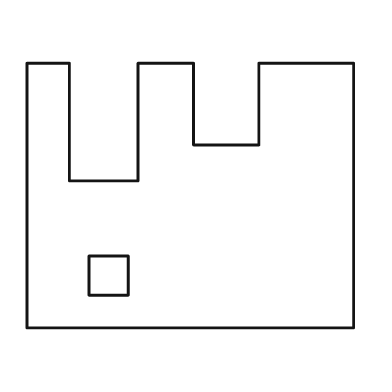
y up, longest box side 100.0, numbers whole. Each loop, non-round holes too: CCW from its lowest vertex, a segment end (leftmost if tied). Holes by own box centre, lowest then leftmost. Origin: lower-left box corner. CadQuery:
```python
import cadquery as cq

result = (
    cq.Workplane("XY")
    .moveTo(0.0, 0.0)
    .lineTo(100.0, 0.0)
    .lineTo(100.0, 81.0)
    .lineTo(71.0, 81.0)
    .lineTo(71.0, 56.0)
    .lineTo(51.0, 56.0)
    .lineTo(51.0, 81.0)
    .lineTo(34.0, 81.0)
    .lineTo(34.0, 45.0)
    .lineTo(13.0, 45.0)
    .lineTo(13.0, 81.0)
    .lineTo(0.0, 81.0)
    .close()
    .moveTo(19.0, 10.0)
    .lineTo(31.0, 10.0)
    .lineTo(31.0, 22.0)
    .lineTo(19.0, 22.0)
    .close()
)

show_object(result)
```